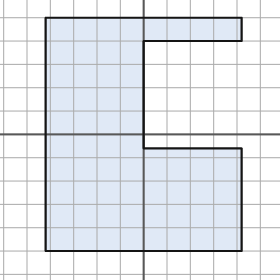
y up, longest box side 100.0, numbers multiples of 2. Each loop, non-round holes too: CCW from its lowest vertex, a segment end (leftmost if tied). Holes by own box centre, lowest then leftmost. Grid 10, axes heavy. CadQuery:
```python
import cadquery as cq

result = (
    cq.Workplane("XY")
    .moveTo(-42.0, -50.0)
    .lineTo(42.0, -50.0)
    .lineTo(42.0, -6.0)
    .lineTo(0.0, -6.0)
    .lineTo(0.0, 40.0)
    .lineTo(42.0, 40.0)
    .lineTo(42.0, 50.0)
    .lineTo(-42.0, 50.0)
    .close()
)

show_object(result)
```